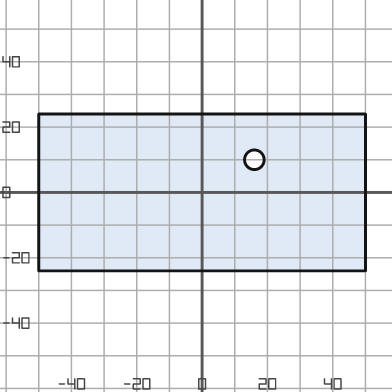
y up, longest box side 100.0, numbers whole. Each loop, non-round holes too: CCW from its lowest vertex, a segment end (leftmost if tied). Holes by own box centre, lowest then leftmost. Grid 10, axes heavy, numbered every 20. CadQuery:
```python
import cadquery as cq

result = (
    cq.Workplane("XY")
    .moveTo(-50.0, -24.0)
    .lineTo(50.0, -24.0)
    .lineTo(50.0, 24.0)
    .lineTo(-50.0, 24.0)
    .close()
    .moveTo(16.0, 10.0)
    .circle(3.0)
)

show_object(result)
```